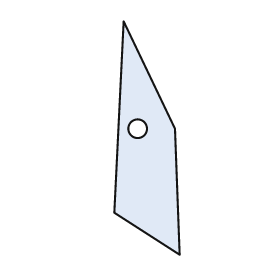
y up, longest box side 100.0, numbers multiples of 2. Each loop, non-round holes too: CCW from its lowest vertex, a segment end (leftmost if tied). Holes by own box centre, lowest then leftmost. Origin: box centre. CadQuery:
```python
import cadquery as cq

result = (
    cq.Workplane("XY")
    .moveTo(14.0, -50.0)
    .lineTo(12.0, 4.0)
    .lineTo(-10.0, 50.0)
    .lineTo(-14.0, -32.0)
    .close()
    .moveTo(-4.0, 4.0)
    .circle(4.0)
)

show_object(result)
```